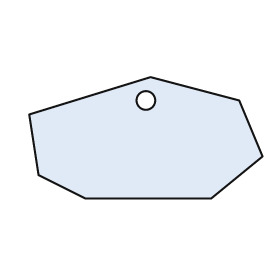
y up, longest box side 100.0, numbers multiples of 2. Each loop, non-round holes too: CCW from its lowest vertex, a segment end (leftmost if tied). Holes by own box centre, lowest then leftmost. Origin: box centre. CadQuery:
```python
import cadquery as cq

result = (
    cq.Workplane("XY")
    .moveTo(-26.0, -26.0)
    .lineTo(28.0, -26.0)
    .lineTo(50.0, -8.0)
    .lineTo(40.0, 16.0)
    .lineTo(2.0, 26.0)
    .lineTo(-50.0, 10.0)
    .lineTo(-46.0, -16.0)
    .close()
    .moveTo(0.0, 16.0)
    .circle(4.0)
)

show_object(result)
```